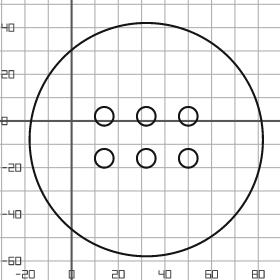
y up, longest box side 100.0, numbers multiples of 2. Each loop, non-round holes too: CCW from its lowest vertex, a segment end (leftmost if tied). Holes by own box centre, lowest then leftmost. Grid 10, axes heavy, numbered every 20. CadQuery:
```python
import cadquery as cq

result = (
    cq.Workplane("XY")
    .moveTo(32.0, -8.0)
    .circle(50.0)
    .moveTo(14.0, -16.0)
    .circle(4.0)
    .moveTo(32.0, -16.0)
    .circle(4.0)
    .moveTo(50.0, -16.0)
    .circle(4.0)
    .moveTo(14.0, 2.0)
    .circle(4.0)
    .moveTo(32.0, 2.0)
    .circle(4.0)
    .moveTo(50.0, 2.0)
    .circle(4.0)
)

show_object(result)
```